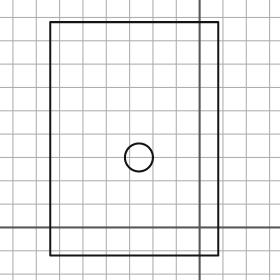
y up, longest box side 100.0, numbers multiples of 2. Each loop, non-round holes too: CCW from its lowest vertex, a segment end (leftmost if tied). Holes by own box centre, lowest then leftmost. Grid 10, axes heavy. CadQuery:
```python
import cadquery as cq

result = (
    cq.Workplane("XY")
    .moveTo(-64.0, -12.0)
    .lineTo(8.0, -12.0)
    .lineTo(8.0, 88.0)
    .lineTo(-64.0, 88.0)
    .close()
    .moveTo(-26.0, 30.0)
    .circle(6.0)
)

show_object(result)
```